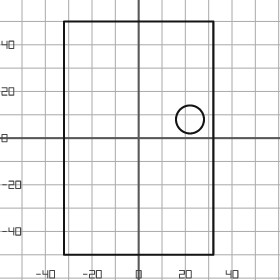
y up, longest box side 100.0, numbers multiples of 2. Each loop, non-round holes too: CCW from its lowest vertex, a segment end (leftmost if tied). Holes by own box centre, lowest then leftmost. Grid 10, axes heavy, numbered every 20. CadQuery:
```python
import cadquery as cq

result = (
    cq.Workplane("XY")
    .moveTo(-32.0, -50.0)
    .lineTo(32.0, -50.0)
    .lineTo(32.0, 50.0)
    .lineTo(-32.0, 50.0)
    .close()
    .moveTo(22.0, 8.0)
    .circle(6.0)
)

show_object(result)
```